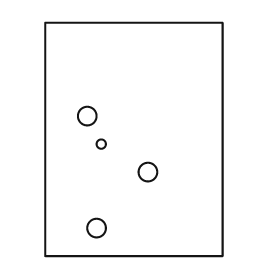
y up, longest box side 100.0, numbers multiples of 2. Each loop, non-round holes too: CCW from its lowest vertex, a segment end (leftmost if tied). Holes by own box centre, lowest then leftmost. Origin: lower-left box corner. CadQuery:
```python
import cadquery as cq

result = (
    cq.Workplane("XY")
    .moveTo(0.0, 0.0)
    .lineTo(76.0, 0.0)
    .lineTo(76.0, 100.0)
    .lineTo(0.0, 100.0)
    .close()
    .moveTo(22.0, 12.0)
    .circle(4.0)
    .moveTo(44.0, 36.0)
    .circle(4.0)
    .moveTo(24.0, 48.0)
    .circle(2.0)
    .moveTo(18.0, 60.0)
    .circle(4.0)
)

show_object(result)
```